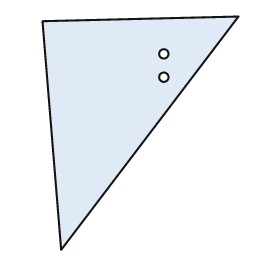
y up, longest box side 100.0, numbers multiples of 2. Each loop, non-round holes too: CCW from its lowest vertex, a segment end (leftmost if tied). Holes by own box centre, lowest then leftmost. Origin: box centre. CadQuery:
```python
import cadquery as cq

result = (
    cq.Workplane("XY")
    .moveTo(-34.0, -50.0)
    .lineTo(42.0, 50.0)
    .lineTo(-42.0, 48.0)
    .close()
    .moveTo(10.0, 24.0)
    .circle(2.0)
    .moveTo(10.0, 34.0)
    .circle(2.0)
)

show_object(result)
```